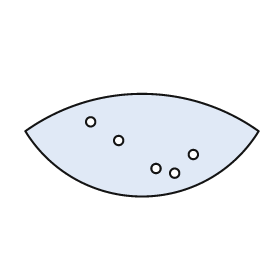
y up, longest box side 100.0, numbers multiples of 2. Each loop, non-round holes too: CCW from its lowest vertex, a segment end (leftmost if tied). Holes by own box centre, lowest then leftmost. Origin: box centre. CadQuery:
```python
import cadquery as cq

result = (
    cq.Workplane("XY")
    .moveTo(-50.0, 6.0)
    .threePointArc((0.0, -22.0), (50.0, 6.0))
    .threePointArc((0.0, 22.0), (-50.0, 6.0))
    .close()
    .moveTo(14.0, -12.0)
    .circle(2.0)
    .moveTo(6.0, -10.0)
    .circle(2.0)
    .moveTo(22.0, -4.0)
    .circle(2.0)
    .moveTo(-10.0, 2.0)
    .circle(2.0)
    .moveTo(-22.0, 10.0)
    .circle(2.0)
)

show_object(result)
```